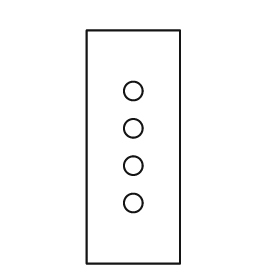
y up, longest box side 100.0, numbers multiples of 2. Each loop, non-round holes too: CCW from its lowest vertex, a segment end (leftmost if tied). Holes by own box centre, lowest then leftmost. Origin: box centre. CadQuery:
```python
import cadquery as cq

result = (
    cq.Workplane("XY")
    .moveTo(-20.0, -50.0)
    .lineTo(20.0, -50.0)
    .lineTo(20.0, 50.0)
    .lineTo(-20.0, 50.0)
    .close()
    .moveTo(0.0, -24.0)
    .circle(4.0)
    .moveTo(0.0, -8.0)
    .circle(4.0)
    .moveTo(0.0, 8.0)
    .circle(4.0)
    .moveTo(0.0, 24.0)
    .circle(4.0)
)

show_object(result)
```